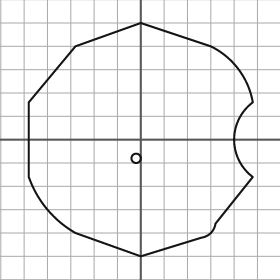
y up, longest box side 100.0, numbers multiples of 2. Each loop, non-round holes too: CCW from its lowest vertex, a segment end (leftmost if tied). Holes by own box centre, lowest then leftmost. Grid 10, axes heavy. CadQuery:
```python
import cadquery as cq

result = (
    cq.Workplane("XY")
    .moveTo(0.0, -50.0)
    .lineTo(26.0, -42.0)
    .threePointArc((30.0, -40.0), (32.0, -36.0))
    .lineTo(48.0, -16.0)
    .threePointArc((40.0, 0.0), (48.0, 16.0))
    .threePointArc((42.0, 30.0), (30.0, 40.0))
    .lineTo(0.0, 50.0)
    .lineTo(-28.0, 40.0)
    .lineTo(-48.0, 16.0)
    .lineTo(-48.0, -16.0)
    .threePointArc((-40.0, -30.0), (-28.0, -40.0))
    .close()
    .moveTo(-2.0, -8.0)
    .circle(2.0)
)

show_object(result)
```